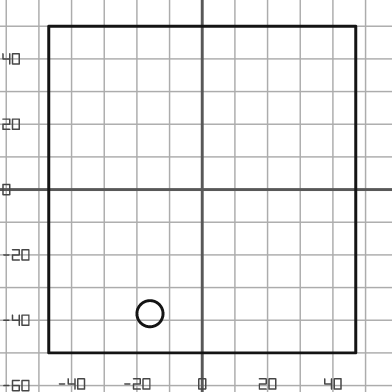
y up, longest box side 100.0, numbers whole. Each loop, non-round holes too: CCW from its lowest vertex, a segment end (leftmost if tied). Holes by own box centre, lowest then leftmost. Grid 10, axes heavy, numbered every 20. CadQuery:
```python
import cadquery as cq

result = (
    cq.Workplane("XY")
    .moveTo(-47.0, -50.0)
    .lineTo(47.0, -50.0)
    .lineTo(47.0, 50.0)
    .lineTo(-47.0, 50.0)
    .close()
    .moveTo(-16.0, -38.0)
    .circle(4.0)
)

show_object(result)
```